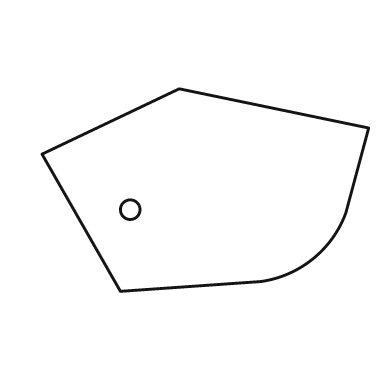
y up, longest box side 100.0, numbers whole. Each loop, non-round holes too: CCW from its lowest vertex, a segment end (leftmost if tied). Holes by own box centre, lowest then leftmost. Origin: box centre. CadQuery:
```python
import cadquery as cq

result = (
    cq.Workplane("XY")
    .moveTo(-26.0, -31.0)
    .lineTo(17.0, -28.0)
    .threePointArc((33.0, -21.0), (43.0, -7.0))
    .lineTo(50.0, 19.0)
    .lineTo(-8.0, 31.0)
    .lineTo(-50.0, 11.0)
    .close()
    .moveTo(-23.0, -6.0)
    .circle(3.0)
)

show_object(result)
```